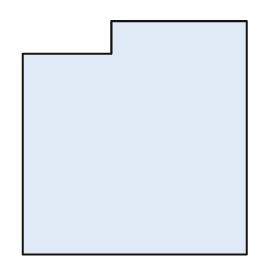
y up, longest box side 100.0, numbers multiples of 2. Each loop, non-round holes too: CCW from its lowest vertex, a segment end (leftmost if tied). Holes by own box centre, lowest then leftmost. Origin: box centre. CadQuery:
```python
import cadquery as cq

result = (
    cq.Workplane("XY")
    .moveTo(-48.0, -50.0)
    .lineTo(48.0, -50.0)
    .lineTo(48.0, 50.0)
    .lineTo(-10.0, 50.0)
    .lineTo(-10.0, 36.0)
    .lineTo(-48.0, 36.0)
    .close()
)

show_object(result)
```